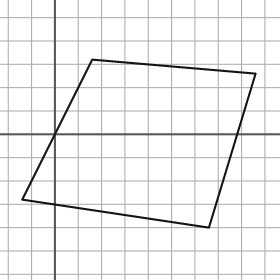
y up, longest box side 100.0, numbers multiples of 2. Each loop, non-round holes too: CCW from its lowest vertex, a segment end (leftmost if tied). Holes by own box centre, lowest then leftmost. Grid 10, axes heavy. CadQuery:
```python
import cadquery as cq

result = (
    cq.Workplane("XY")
    .moveTo(66.0, -40.0)
    .lineTo(86.0, 26.0)
    .lineTo(16.0, 32.0)
    .lineTo(-14.0, -28.0)
    .close()
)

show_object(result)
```